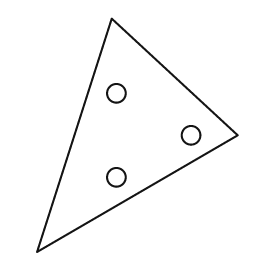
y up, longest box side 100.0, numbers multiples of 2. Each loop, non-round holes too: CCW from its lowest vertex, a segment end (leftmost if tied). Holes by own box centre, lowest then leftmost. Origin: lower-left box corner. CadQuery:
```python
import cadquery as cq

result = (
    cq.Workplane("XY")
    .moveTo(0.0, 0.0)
    .lineTo(86.0, 50.0)
    .lineTo(32.0, 100.0)
    .close()
    .moveTo(34.0, 32.0)
    .circle(4.0)
    .moveTo(66.0, 50.0)
    .circle(4.0)
    .moveTo(34.0, 68.0)
    .circle(4.0)
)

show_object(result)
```